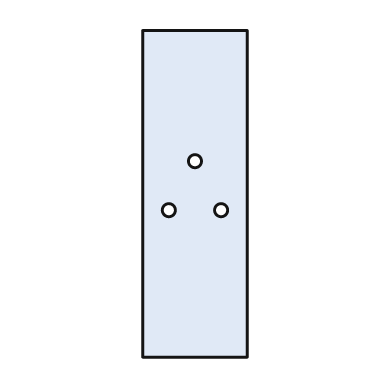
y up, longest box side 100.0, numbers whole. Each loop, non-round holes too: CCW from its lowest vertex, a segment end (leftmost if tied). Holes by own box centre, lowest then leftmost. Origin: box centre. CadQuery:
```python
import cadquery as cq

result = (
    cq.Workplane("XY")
    .moveTo(-16.0, -50.0)
    .lineTo(16.0, -50.0)
    .lineTo(16.0, 50.0)
    .lineTo(-16.0, 50.0)
    .close()
    .moveTo(-8.0, -5.0)
    .circle(2.0)
    .moveTo(8.0, -5.0)
    .circle(2.0)
    .moveTo(0.0, 10.0)
    .circle(2.0)
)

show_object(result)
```